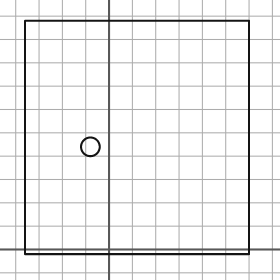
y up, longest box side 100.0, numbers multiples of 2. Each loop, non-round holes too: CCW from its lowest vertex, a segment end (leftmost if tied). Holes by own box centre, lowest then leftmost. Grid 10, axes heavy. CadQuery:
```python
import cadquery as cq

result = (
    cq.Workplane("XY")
    .moveTo(-36.0, -2.0)
    .lineTo(60.0, -2.0)
    .lineTo(60.0, 98.0)
    .lineTo(-36.0, 98.0)
    .close()
    .moveTo(-8.0, 44.0)
    .circle(4.0)
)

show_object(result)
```